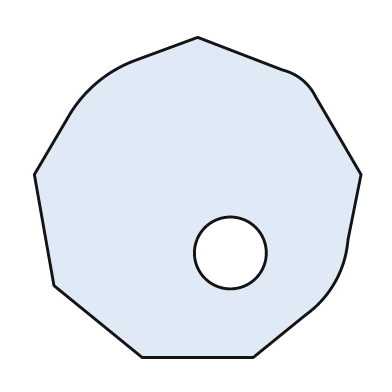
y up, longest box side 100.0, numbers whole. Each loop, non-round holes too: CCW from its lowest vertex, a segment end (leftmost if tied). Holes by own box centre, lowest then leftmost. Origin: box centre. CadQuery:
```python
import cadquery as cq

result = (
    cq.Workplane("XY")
    .moveTo(-17.0, -49.0)
    .lineTo(17.0, -49.0)
    .lineTo(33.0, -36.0)
    .threePointArc((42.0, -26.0), (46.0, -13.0))
    .lineTo(50.0, 7.0)
    .lineTo(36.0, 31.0)
    .threePointArc((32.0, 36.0), (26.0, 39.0))
    .lineTo(0.0, 49.0)
    .lineTo(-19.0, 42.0)
    .threePointArc((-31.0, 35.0), (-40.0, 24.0))
    .lineTo(-50.0, 7.0)
    .lineTo(-44.0, -27.0)
    .close()
    .moveTo(10.0, -17.0)
    .circle(11.0)
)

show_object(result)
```